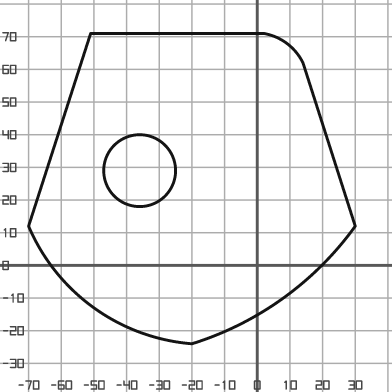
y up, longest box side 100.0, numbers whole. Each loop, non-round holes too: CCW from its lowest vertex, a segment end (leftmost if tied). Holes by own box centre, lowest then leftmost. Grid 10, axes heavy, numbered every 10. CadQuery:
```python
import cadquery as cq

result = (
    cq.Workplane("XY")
    .moveTo(-20.0, -24.0)
    .threePointArc((8.0, -10.0), (30.0, 12.0))
    .lineTo(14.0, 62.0)
    .threePointArc((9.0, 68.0), (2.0, 71.0))
    .lineTo(-51.0, 71.0)
    .lineTo(-70.0, 12.0)
    .threePointArc((-50.0, -13.0), (-20.0, -24.0))
    .close()
    .moveTo(-36.0, 29.0)
    .circle(11.0)
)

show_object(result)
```